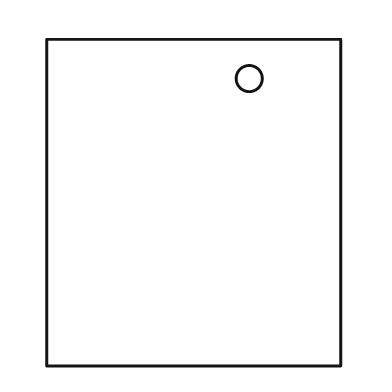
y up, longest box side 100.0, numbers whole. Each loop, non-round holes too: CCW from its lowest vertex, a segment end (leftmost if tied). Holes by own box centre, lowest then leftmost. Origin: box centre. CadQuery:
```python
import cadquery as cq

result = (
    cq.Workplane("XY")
    .moveTo(-45.0, -50.0)
    .lineTo(45.0, -50.0)
    .lineTo(45.0, 50.0)
    .lineTo(-45.0, 50.0)
    .close()
    .moveTo(17.0, 38.0)
    .circle(4.0)
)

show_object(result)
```